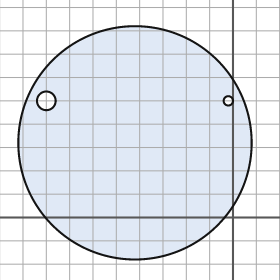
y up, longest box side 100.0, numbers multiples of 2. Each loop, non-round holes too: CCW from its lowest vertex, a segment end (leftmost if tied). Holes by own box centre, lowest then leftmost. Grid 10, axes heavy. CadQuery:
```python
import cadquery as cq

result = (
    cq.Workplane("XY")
    .moveTo(-42.0, 32.0)
    .circle(50.0)
    .moveTo(-80.0, 50.0)
    .circle(4.0)
    .moveTo(-2.0, 50.0)
    .circle(2.0)
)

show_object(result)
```